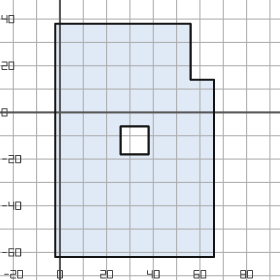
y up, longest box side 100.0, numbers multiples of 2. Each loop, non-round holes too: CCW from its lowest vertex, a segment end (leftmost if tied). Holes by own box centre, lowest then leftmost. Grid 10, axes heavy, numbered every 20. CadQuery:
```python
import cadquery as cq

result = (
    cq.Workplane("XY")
    .moveTo(-2.0, -62.0)
    .lineTo(66.0, -62.0)
    .lineTo(66.0, 14.0)
    .lineTo(56.0, 14.0)
    .lineTo(56.0, 38.0)
    .lineTo(-2.0, 38.0)
    .close()
    .moveTo(26.0, -18.0)
    .lineTo(38.0, -18.0)
    .lineTo(38.0, -6.0)
    .lineTo(26.0, -6.0)
    .close()
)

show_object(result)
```